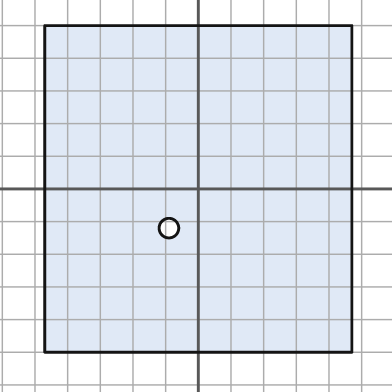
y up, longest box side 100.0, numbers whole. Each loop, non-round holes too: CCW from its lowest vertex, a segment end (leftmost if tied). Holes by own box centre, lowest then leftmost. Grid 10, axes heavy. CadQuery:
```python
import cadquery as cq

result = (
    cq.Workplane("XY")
    .moveTo(-47.0, -50.0)
    .lineTo(47.0, -50.0)
    .lineTo(47.0, 50.0)
    .lineTo(-47.0, 50.0)
    .close()
    .moveTo(-9.0, -12.0)
    .circle(3.0)
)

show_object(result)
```